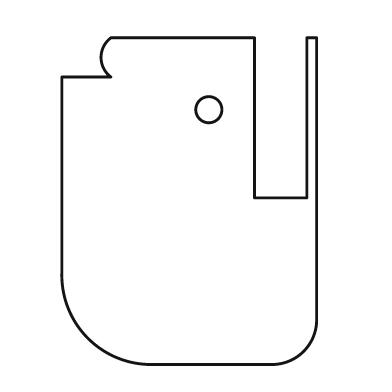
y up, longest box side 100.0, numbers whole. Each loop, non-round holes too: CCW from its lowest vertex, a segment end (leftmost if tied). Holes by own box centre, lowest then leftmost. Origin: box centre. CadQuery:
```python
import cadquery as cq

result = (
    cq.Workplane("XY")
    .moveTo(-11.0, -50.0)
    .lineTo(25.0, -50.0)
    .threePointArc((35.0, -46.0), (39.0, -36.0))
    .lineTo(39.0, 50.0)
    .lineTo(36.0, 50.0)
    .lineTo(36.0, 1.0)
    .lineTo(20.0, 1.0)
    .lineTo(20.0, 50.0)
    .lineTo(-24.0, 50.0)
    .threePointArc((-27.0, 44.0), (-24.0, 38.0))
    .lineTo(-39.0, 38.0)
    .lineTo(-39.0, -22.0)
    .threePointArc((-31.0, -42.0), (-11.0, -50.0))
    .close()
    .moveTo(6.0, 28.0)
    .circle(4.0)
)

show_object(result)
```